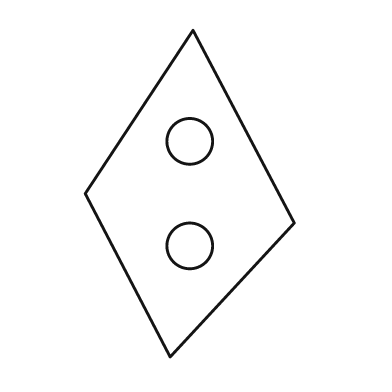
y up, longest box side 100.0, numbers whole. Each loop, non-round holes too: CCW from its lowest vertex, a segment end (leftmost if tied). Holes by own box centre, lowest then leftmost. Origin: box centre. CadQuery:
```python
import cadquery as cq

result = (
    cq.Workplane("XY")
    .moveTo(-6.0, -50.0)
    .lineTo(32.0, -9.0)
    .lineTo(1.0, 50.0)
    .lineTo(-32.0, 0.0)
    .close()
    .moveTo(0.0, -16.0)
    .circle(7.0)
    .moveTo(0.0, 16.0)
    .circle(7.0)
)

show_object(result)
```